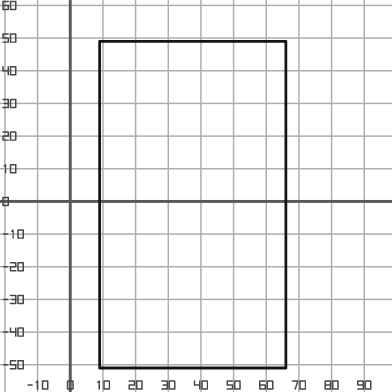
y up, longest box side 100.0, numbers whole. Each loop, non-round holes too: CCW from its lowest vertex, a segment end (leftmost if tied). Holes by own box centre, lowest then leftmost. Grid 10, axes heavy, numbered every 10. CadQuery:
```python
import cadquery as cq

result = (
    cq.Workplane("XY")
    .moveTo(9.0, -51.0)
    .lineTo(66.0, -51.0)
    .lineTo(66.0, 49.0)
    .lineTo(9.0, 49.0)
    .close()
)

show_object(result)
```